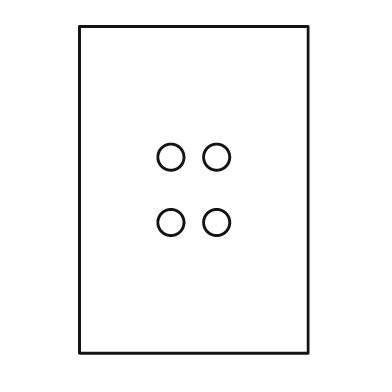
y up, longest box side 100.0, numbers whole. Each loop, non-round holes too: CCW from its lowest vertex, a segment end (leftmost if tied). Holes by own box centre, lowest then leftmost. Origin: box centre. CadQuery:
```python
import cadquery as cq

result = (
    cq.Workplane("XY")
    .moveTo(-35.0, -50.0)
    .lineTo(35.0, -50.0)
    .lineTo(35.0, 50.0)
    .lineTo(-35.0, 50.0)
    .close()
    .moveTo(-7.0, -10.0)
    .circle(4.0)
    .moveTo(7.0, -10.0)
    .circle(4.0)
    .moveTo(-7.0, 10.0)
    .circle(4.0)
    .moveTo(7.0, 10.0)
    .circle(4.0)
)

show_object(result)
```